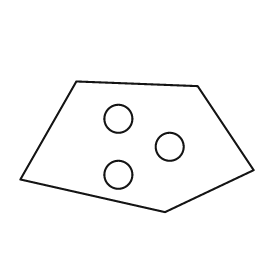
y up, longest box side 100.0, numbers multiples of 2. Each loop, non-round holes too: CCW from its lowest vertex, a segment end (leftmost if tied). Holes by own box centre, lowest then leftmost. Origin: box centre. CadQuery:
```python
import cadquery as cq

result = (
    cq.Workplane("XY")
    .moveTo(12.0, -28.0)
    .lineTo(50.0, -10.0)
    .lineTo(26.0, 26.0)
    .lineTo(-26.0, 28.0)
    .lineTo(-50.0, -14.0)
    .close()
    .moveTo(-8.0, -12.0)
    .circle(6.0)
    .moveTo(14.0, 0.0)
    .circle(6.0)
    .moveTo(-8.0, 12.0)
    .circle(6.0)
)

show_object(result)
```